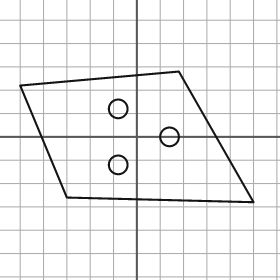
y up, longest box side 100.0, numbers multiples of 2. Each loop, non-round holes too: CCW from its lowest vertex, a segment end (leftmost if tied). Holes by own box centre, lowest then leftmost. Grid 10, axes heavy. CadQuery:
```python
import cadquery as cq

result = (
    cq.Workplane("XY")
    .moveTo(50.0, -28.0)
    .lineTo(18.0, 28.0)
    .lineTo(-50.0, 22.0)
    .lineTo(-30.0, -26.0)
    .close()
    .moveTo(-8.0, -12.0)
    .circle(4.0)
    .moveTo(14.0, 0.0)
    .circle(4.0)
    .moveTo(-8.0, 12.0)
    .circle(4.0)
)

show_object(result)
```